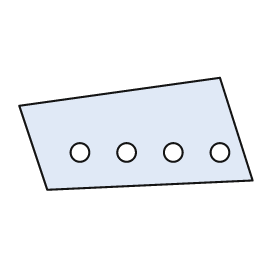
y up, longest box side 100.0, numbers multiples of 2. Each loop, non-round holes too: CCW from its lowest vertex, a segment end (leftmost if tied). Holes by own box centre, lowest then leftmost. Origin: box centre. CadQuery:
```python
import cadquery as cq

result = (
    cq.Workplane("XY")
    .moveTo(-38.0, -24.0)
    .lineTo(50.0, -20.0)
    .lineTo(36.0, 24.0)
    .lineTo(-50.0, 12.0)
    .close()
    .moveTo(-24.0, -8.0)
    .circle(4.0)
    .moveTo(-4.0, -8.0)
    .circle(4.0)
    .moveTo(16.0, -8.0)
    .circle(4.0)
    .moveTo(36.0, -8.0)
    .circle(4.0)
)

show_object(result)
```